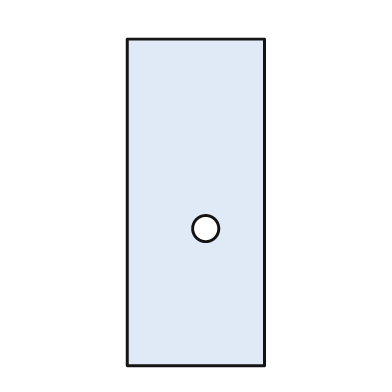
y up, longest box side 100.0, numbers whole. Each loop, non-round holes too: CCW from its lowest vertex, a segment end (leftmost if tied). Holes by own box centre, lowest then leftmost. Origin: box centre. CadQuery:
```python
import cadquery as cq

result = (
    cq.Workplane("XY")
    .moveTo(-21.0, -50.0)
    .lineTo(21.0, -50.0)
    .lineTo(21.0, 50.0)
    .lineTo(-21.0, 50.0)
    .close()
    .moveTo(3.0, -8.0)
    .circle(4.0)
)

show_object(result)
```